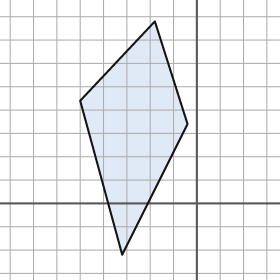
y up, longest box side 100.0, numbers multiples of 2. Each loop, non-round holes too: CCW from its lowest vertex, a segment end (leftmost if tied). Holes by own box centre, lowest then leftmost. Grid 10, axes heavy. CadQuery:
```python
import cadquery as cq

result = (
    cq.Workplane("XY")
    .moveTo(-32.0, -22.0)
    .lineTo(-4.0, 34.0)
    .lineTo(-18.0, 78.0)
    .lineTo(-50.0, 44.0)
    .close()
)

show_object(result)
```